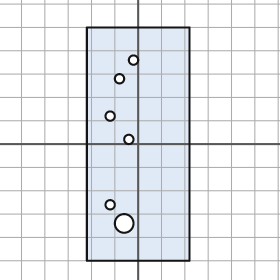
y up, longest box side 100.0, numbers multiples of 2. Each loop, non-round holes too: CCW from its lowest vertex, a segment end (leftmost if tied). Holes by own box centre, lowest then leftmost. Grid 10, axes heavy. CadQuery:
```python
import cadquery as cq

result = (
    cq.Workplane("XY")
    .moveTo(-22.0, -50.0)
    .lineTo(22.0, -50.0)
    .lineTo(22.0, 50.0)
    .lineTo(-22.0, 50.0)
    .close()
    .moveTo(-6.0, -34.0)
    .circle(4.0)
    .moveTo(-12.0, -26.0)
    .circle(2.0)
    .moveTo(-4.0, 2.0)
    .circle(2.0)
    .moveTo(-12.0, 12.0)
    .circle(2.0)
    .moveTo(-8.0, 28.0)
    .circle(2.0)
    .moveTo(-2.0, 36.0)
    .circle(2.0)
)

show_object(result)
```